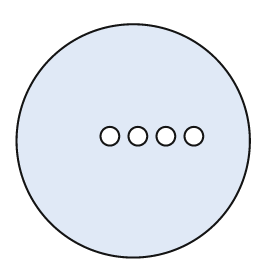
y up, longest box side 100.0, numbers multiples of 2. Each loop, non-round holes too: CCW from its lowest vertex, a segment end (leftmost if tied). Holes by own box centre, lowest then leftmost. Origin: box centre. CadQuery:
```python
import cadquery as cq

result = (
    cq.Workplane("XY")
    .moveTo(0.0, 0.0)
    .circle(50.0)
    .moveTo(-10.0, 2.0)
    .circle(4.0)
    .moveTo(2.0, 2.0)
    .circle(4.0)
    .moveTo(14.0, 2.0)
    .circle(4.0)
    .moveTo(26.0, 2.0)
    .circle(4.0)
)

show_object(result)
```